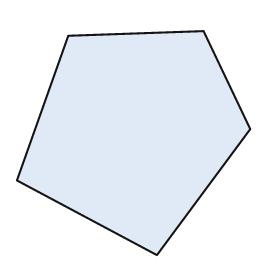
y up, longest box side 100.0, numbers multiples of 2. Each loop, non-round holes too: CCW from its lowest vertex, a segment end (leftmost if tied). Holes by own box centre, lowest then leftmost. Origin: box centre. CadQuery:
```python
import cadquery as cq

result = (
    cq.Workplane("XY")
    .moveTo(10.0, -48.0)
    .lineTo(50.0, 6.0)
    .lineTo(30.0, 48.0)
    .lineTo(-28.0, 46.0)
    .lineTo(-50.0, -16.0)
    .close()
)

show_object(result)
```